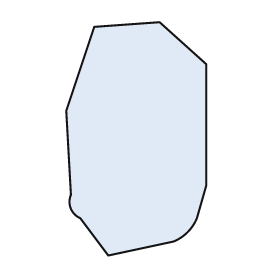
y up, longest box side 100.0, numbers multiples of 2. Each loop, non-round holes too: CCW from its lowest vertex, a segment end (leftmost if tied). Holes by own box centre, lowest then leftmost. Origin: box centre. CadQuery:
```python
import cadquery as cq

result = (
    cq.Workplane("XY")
    .moveTo(-12.0, -50.0)
    .lineTo(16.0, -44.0)
    .threePointArc((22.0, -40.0), (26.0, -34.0))
    .lineTo(30.0, -20.0)
    .lineTo(30.0, 32.0)
    .lineTo(10.0, 50.0)
    .lineTo(-18.0, 48.0)
    .lineTo(-30.0, 12.0)
    .lineTo(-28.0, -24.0)
    .threePointArc((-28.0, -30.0), (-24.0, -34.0))
    .close()
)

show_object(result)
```